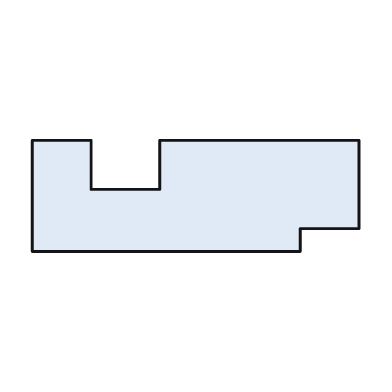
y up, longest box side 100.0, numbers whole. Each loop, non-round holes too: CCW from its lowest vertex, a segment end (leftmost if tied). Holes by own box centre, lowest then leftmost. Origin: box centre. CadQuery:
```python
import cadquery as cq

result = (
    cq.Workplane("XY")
    .moveTo(-50.0, -17.0)
    .lineTo(32.0, -17.0)
    .lineTo(32.0, -10.0)
    .lineTo(50.0, -10.0)
    .lineTo(50.0, 17.0)
    .lineTo(-11.0, 17.0)
    .lineTo(-11.0, 2.0)
    .lineTo(-32.0, 2.0)
    .lineTo(-32.0, 17.0)
    .lineTo(-50.0, 17.0)
    .close()
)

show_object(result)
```